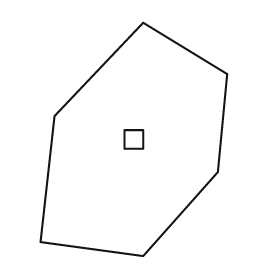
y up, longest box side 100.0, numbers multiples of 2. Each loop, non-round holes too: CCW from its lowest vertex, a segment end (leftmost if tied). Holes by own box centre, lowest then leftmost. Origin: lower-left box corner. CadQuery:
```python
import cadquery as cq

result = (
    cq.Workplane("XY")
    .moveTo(44.0, 0.0)
    .lineTo(76.0, 36.0)
    .lineTo(80.0, 78.0)
    .lineTo(44.0, 100.0)
    .lineTo(6.0, 60.0)
    .lineTo(0.0, 6.0)
    .close()
    .moveTo(36.0, 46.0)
    .lineTo(44.0, 46.0)
    .lineTo(44.0, 54.0)
    .lineTo(36.0, 54.0)
    .close()
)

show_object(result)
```